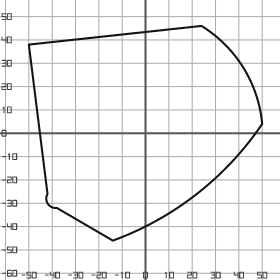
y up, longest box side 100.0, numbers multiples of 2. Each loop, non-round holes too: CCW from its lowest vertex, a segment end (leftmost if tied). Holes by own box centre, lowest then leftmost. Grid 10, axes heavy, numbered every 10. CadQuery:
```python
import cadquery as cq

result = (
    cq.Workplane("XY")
    .moveTo(-14.0, -46.0)
    .threePointArc((22.0, -26.0), (50.0, 4.0))
    .threePointArc((42.0, 28.0), (24.0, 46.0))
    .lineTo(-50.0, 38.0)
    .lineTo(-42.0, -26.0)
    .threePointArc((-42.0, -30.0), (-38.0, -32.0))
    .close()
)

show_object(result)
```